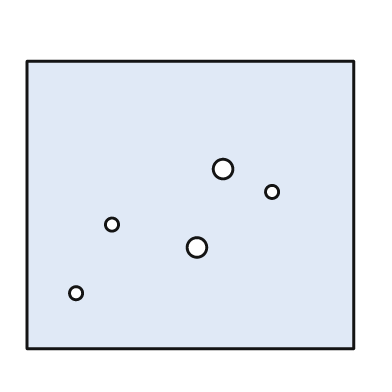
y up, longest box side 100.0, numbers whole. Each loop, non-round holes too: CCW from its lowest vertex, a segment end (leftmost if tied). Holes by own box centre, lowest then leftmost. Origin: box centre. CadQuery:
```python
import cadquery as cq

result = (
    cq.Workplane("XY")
    .moveTo(-50.0, -44.0)
    .lineTo(50.0, -44.0)
    .lineTo(50.0, 44.0)
    .lineTo(-50.0, 44.0)
    .close()
    .moveTo(-35.0, -27.0)
    .circle(2.0)
    .moveTo(2.0, -13.0)
    .circle(3.0)
    .moveTo(-24.0, -6.0)
    .circle(2.0)
    .moveTo(25.0, 4.0)
    .circle(2.0)
    .moveTo(10.0, 11.0)
    .circle(3.0)
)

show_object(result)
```